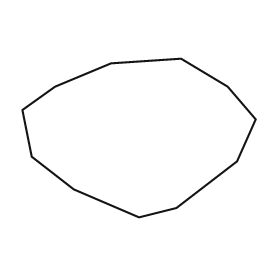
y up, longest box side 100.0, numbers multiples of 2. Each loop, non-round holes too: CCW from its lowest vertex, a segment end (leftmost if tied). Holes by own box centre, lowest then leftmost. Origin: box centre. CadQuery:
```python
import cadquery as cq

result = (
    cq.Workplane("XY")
    .moveTo(0.0, -34.0)
    .lineTo(16.0, -30.0)
    .lineTo(42.0, -10.0)
    .lineTo(50.0, 8.0)
    .lineTo(38.0, 22.0)
    .lineTo(18.0, 34.0)
    .lineTo(-12.0, 32.0)
    .lineTo(-36.0, 22.0)
    .lineTo(-50.0, 12.0)
    .lineTo(-46.0, -8.0)
    .lineTo(-28.0, -22.0)
    .close()
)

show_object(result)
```